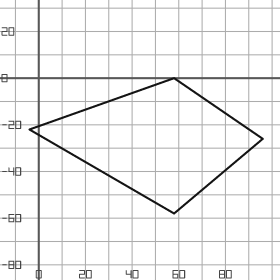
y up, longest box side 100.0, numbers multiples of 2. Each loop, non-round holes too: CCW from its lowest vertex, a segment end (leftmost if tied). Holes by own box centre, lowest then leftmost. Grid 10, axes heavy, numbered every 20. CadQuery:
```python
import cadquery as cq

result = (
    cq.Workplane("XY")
    .moveTo(58.0, -58.0)
    .lineTo(96.0, -26.0)
    .lineTo(58.0, 0.0)
    .lineTo(-4.0, -22.0)
    .close()
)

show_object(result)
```